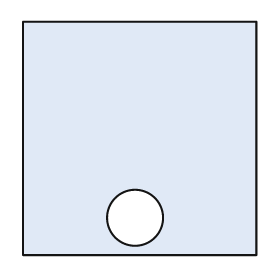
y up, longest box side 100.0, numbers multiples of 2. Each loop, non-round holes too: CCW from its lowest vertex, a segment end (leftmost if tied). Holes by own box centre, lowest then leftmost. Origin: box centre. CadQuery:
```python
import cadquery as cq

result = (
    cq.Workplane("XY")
    .moveTo(-50.0, -50.0)
    .lineTo(50.0, -50.0)
    .lineTo(50.0, 50.0)
    .lineTo(-50.0, 50.0)
    .close()
    .moveTo(-2.0, -34.0)
    .circle(12.0)
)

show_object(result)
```